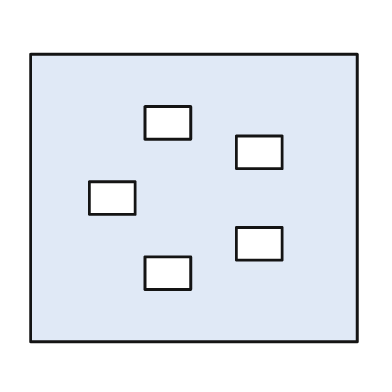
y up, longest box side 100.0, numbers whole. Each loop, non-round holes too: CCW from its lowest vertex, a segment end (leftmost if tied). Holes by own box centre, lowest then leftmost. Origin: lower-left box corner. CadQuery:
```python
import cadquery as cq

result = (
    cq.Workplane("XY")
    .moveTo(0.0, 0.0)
    .lineTo(100.0, 0.0)
    .lineTo(100.0, 88.0)
    .lineTo(0.0, 88.0)
    .close()
    .moveTo(35.0, 16.0)
    .lineTo(49.0, 16.0)
    .lineTo(49.0, 26.0)
    .lineTo(35.0, 26.0)
    .close()
    .moveTo(63.0, 25.0)
    .lineTo(77.0, 25.0)
    .lineTo(77.0, 35.0)
    .lineTo(63.0, 35.0)
    .close()
    .moveTo(18.0, 39.0)
    .lineTo(32.0, 39.0)
    .lineTo(32.0, 49.0)
    .lineTo(18.0, 49.0)
    .close()
    .moveTo(63.0, 53.0)
    .lineTo(77.0, 53.0)
    .lineTo(77.0, 63.0)
    .lineTo(63.0, 63.0)
    .close()
    .moveTo(35.0, 62.0)
    .lineTo(49.0, 62.0)
    .lineTo(49.0, 72.0)
    .lineTo(35.0, 72.0)
    .close()
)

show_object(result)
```